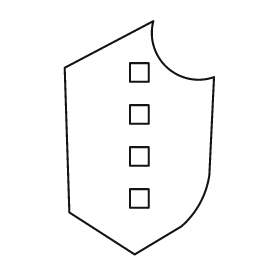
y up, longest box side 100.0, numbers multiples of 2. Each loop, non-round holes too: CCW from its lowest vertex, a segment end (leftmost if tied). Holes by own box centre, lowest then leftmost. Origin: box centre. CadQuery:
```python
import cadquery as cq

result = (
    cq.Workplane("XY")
    .moveTo(-2.0, -50.0)
    .lineTo(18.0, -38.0)
    .threePointArc((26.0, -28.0), (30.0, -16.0))
    .lineTo(32.0, 26.0)
    .threePointArc((12.0, 30.0), (6.0, 50.0))
    .lineTo(-32.0, 30.0)
    .lineTo(-30.0, -32.0)
    .close()
    .moveTo(-4.0, -30.0)
    .lineTo(4.0, -30.0)
    .lineTo(4.0, -22.0)
    .lineTo(-4.0, -22.0)
    .close()
    .moveTo(-4.0, -12.0)
    .lineTo(4.0, -12.0)
    .lineTo(4.0, -4.0)
    .lineTo(-4.0, -4.0)
    .close()
    .moveTo(-4.0, 6.0)
    .lineTo(4.0, 6.0)
    .lineTo(4.0, 14.0)
    .lineTo(-4.0, 14.0)
    .close()
    .moveTo(-4.0, 24.0)
    .lineTo(4.0, 24.0)
    .lineTo(4.0, 32.0)
    .lineTo(-4.0, 32.0)
    .close()
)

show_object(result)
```